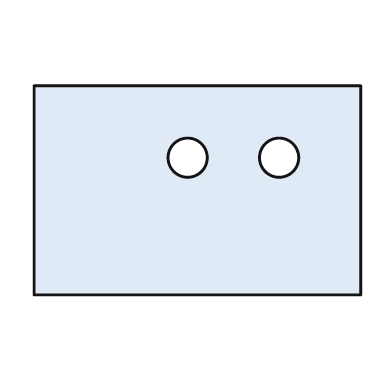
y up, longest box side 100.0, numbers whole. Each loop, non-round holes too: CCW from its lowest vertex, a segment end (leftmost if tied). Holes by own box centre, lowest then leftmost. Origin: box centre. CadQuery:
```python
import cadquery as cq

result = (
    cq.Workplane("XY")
    .moveTo(-50.0, -32.0)
    .lineTo(50.0, -32.0)
    .lineTo(50.0, 32.0)
    .lineTo(-50.0, 32.0)
    .close()
    .moveTo(-3.0, 10.0)
    .circle(6.0)
    .moveTo(25.0, 10.0)
    .circle(6.0)
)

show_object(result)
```